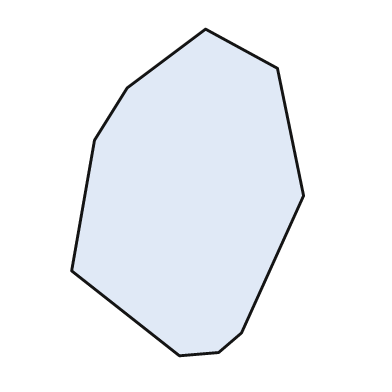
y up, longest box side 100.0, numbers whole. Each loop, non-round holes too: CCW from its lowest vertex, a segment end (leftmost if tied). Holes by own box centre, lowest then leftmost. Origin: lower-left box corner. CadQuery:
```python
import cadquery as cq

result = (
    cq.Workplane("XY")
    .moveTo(33.0, 0.0)
    .lineTo(45.0, 1.0)
    .lineTo(52.0, 7.0)
    .lineTo(71.0, 49.0)
    .lineTo(63.0, 88.0)
    .lineTo(41.0, 100.0)
    .lineTo(17.0, 82.0)
    .lineTo(7.0, 66.0)
    .lineTo(0.0, 26.0)
    .close()
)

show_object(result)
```